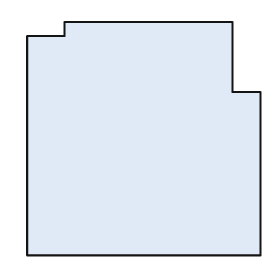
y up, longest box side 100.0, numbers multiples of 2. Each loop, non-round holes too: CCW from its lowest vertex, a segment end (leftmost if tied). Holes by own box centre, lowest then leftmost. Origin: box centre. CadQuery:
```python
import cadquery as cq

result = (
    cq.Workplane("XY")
    .moveTo(-50.0, -50.0)
    .lineTo(50.0, -50.0)
    .lineTo(50.0, 20.0)
    .lineTo(38.0, 20.0)
    .lineTo(38.0, 50.0)
    .lineTo(-34.0, 50.0)
    .lineTo(-34.0, 44.0)
    .lineTo(-50.0, 44.0)
    .close()
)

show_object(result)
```